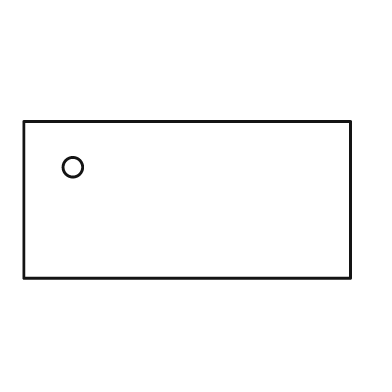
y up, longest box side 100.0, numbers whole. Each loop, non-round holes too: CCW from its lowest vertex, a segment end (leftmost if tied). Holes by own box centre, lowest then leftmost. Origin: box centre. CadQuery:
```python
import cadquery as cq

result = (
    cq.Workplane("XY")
    .moveTo(-50.0, -24.0)
    .lineTo(50.0, -24.0)
    .lineTo(50.0, 24.0)
    .lineTo(-50.0, 24.0)
    .close()
    .moveTo(-35.0, 10.0)
    .circle(3.0)
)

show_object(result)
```